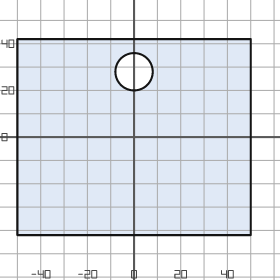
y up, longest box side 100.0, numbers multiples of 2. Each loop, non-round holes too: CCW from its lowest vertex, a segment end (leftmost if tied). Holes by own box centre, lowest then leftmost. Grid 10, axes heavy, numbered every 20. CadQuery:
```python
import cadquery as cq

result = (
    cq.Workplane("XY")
    .moveTo(-50.0, -42.0)
    .lineTo(50.0, -42.0)
    .lineTo(50.0, 42.0)
    .lineTo(-50.0, 42.0)
    .close()
    .moveTo(0.0, 28.0)
    .circle(8.0)
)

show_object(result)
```